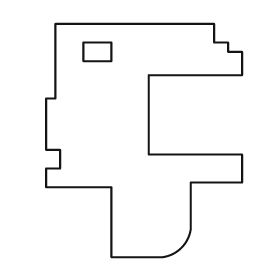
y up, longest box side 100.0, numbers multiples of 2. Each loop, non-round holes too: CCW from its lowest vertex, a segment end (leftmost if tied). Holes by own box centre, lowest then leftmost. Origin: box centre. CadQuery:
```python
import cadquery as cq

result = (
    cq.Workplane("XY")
    .moveTo(-14.0, -50.0)
    .lineTo(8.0, -50.0)
    .threePointArc((16.0, -46.0), (20.0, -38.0))
    .lineTo(20.0, -18.0)
    .lineTo(42.0, -18.0)
    .lineTo(42.0, -6.0)
    .lineTo(2.0, -6.0)
    .lineTo(2.0, 28.0)
    .lineTo(42.0, 28.0)
    .lineTo(42.0, 38.0)
    .lineTo(36.0, 38.0)
    .lineTo(36.0, 42.0)
    .lineTo(30.0, 42.0)
    .lineTo(30.0, 50.0)
    .lineTo(-38.0, 50.0)
    .lineTo(-38.0, 18.0)
    .lineTo(-42.0, 18.0)
    .lineTo(-42.0, -4.0)
    .lineTo(-36.0, -4.0)
    .lineTo(-36.0, -12.0)
    .lineTo(-42.0, -12.0)
    .lineTo(-42.0, -20.0)
    .lineTo(-14.0, -20.0)
    .close()
    .moveTo(-26.0, 34.0)
    .lineTo(-14.0, 34.0)
    .lineTo(-14.0, 42.0)
    .lineTo(-26.0, 42.0)
    .close()
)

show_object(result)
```